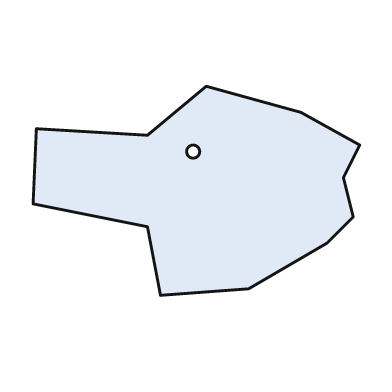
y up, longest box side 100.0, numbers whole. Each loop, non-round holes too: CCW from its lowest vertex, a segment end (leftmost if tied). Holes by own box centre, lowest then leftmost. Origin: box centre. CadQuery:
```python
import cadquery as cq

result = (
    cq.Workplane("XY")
    .moveTo(-11.0, -32.0)
    .lineTo(16.0, -30.0)
    .lineTo(40.0, -16.0)
    .lineTo(48.0, -8.0)
    .lineTo(45.0, 4.0)
    .lineTo(50.0, 14.0)
    .lineTo(32.0, 24.0)
    .lineTo(3.0, 32.0)
    .lineTo(-15.0, 17.0)
    .lineTo(-49.0, 19.0)
    .lineTo(-50.0, -4.0)
    .lineTo(-15.0, -11.0)
    .close()
    .moveTo(-1.0, 12.0)
    .circle(2.0)
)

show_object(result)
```